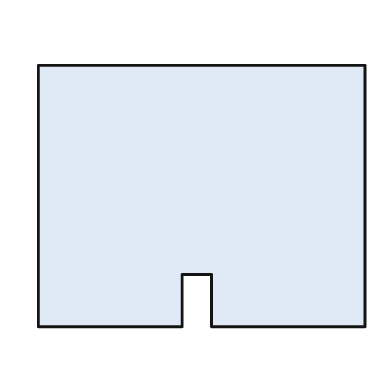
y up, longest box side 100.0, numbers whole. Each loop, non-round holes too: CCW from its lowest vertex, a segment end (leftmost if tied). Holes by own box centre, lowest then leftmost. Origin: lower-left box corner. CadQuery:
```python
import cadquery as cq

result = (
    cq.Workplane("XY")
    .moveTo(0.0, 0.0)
    .lineTo(44.0, 0.0)
    .lineTo(44.0, 16.0)
    .lineTo(53.0, 16.0)
    .lineTo(53.0, 0.0)
    .lineTo(100.0, 0.0)
    .lineTo(100.0, 80.0)
    .lineTo(0.0, 80.0)
    .close()
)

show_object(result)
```